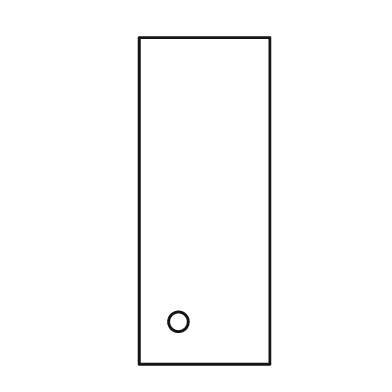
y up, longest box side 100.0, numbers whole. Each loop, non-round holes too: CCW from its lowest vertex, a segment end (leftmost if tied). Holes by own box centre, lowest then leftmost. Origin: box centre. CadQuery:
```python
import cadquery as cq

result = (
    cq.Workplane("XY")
    .moveTo(-20.0, -50.0)
    .lineTo(20.0, -50.0)
    .lineTo(20.0, 50.0)
    .lineTo(-20.0, 50.0)
    .close()
    .moveTo(-8.0, -37.0)
    .circle(3.0)
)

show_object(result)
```